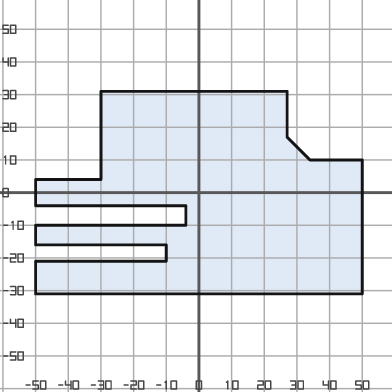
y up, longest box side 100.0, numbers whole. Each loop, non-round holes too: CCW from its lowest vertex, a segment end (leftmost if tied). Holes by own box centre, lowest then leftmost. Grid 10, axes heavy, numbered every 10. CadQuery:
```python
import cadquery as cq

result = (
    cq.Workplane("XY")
    .moveTo(-50.0, -31.0)
    .lineTo(50.0, -31.0)
    .lineTo(50.0, 10.0)
    .lineTo(34.0, 10.0)
    .lineTo(27.0, 17.0)
    .lineTo(27.0, 31.0)
    .lineTo(-30.0, 31.0)
    .lineTo(-30.0, 4.0)
    .lineTo(-50.0, 4.0)
    .lineTo(-50.0, -4.0)
    .lineTo(-4.0, -4.0)
    .lineTo(-4.0, -10.0)
    .lineTo(-50.0, -10.0)
    .lineTo(-50.0, -16.0)
    .lineTo(-10.0, -16.0)
    .lineTo(-10.0, -21.0)
    .lineTo(-50.0, -21.0)
    .close()
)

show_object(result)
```